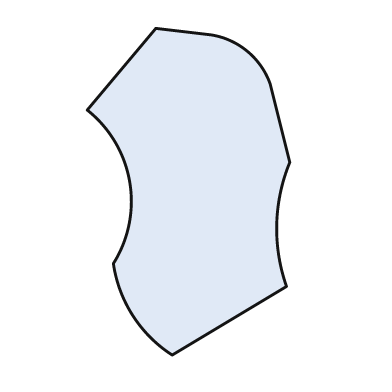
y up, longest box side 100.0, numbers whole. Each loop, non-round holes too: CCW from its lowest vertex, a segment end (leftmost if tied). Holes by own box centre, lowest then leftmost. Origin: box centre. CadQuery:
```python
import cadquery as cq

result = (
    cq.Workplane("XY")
    .moveTo(-5.0, -50.0)
    .lineTo(30.0, -29.0)
    .threePointArc((27.0, -10.0), (31.0, 9.0))
    .lineTo(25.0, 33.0)
    .threePointArc((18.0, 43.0), (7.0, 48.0))
    .lineTo(-10.0, 50.0)
    .lineTo(-31.0, 25.0)
    .threePointArc((-18.0, 3.0), (-23.0, -22.0))
    .threePointArc((-17.0, -38.0), (-5.0, -50.0))
    .close()
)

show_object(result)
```